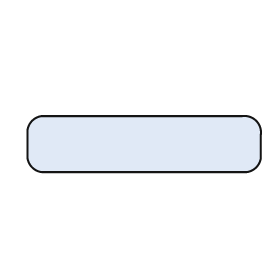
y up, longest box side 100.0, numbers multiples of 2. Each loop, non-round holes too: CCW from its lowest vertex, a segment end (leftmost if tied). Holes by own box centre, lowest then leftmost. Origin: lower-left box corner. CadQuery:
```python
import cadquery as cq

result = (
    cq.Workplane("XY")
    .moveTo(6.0, 0.0)
    .lineTo(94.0, 0.0)
    .threePointArc((98.0, 2.0), (100.0, 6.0))
    .lineTo(100.0, 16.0)
    .threePointArc((98.0, 22.0), (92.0, 24.0))
    .lineTo(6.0, 24.0)
    .threePointArc((2.0, 22.0), (0.0, 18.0))
    .lineTo(0.0, 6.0)
    .threePointArc((2.0, 2.0), (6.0, 0.0))
    .close()
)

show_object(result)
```